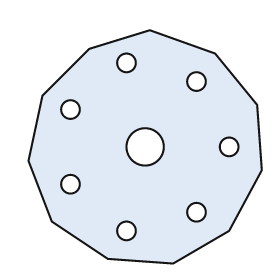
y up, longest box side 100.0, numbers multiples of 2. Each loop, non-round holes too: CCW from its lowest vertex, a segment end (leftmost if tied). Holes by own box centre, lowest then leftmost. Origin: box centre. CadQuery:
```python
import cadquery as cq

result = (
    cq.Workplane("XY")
    .moveTo(12.0, -50.0)
    .lineTo(36.0, -36.0)
    .lineTo(50.0, -10.0)
    .lineTo(48.0, 18.0)
    .lineTo(30.0, 40.0)
    .lineTo(2.0, 50.0)
    .lineTo(-24.0, 42.0)
    .lineTo(-44.0, 22.0)
    .lineTo(-50.0, -6.0)
    .lineTo(-40.0, -32.0)
    .lineTo(-16.0, -48.0)
    .close()
    .moveTo(-8.0, -36.0)
    .circle(4.0)
    .moveTo(22.0, -28.0)
    .circle(4.0)
    .moveTo(-32.0, -16.0)
    .circle(4.0)
    .moveTo(0.0, 0.0)
    .circle(8.0)
    .moveTo(36.0, 0.0)
    .circle(4.0)
    .moveTo(-32.0, 16.0)
    .circle(4.0)
    .moveTo(22.0, 28.0)
    .circle(4.0)
    .moveTo(-8.0, 36.0)
    .circle(4.0)
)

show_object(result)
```